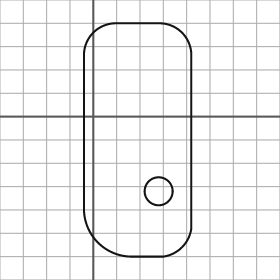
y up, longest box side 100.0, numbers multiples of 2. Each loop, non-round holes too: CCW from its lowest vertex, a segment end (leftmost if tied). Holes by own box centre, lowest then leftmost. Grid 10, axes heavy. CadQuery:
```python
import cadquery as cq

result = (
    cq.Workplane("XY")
    .moveTo(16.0, -60.0)
    .lineTo(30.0, -60.0)
    .threePointArc((38.0, -56.0), (42.0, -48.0))
    .lineTo(42.0, 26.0)
    .threePointArc((38.0, 36.0), (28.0, 40.0))
    .lineTo(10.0, 40.0)
    .threePointArc((0.0, 36.0), (-4.0, 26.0))
    .lineTo(-4.0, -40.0)
    .threePointArc((2.0, -54.0), (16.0, -60.0))
    .close()
    .moveTo(28.0, -32.0)
    .circle(6.0)
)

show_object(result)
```